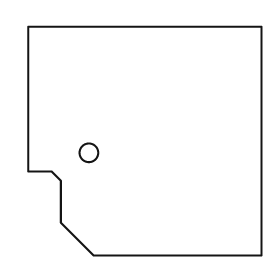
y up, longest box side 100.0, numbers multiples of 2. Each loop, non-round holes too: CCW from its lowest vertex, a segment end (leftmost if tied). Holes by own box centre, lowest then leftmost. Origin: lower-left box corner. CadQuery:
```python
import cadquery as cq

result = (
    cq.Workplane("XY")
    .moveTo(28.0, 0.0)
    .lineTo(100.0, 0.0)
    .lineTo(100.0, 98.0)
    .lineTo(0.0, 98.0)
    .lineTo(0.0, 36.0)
    .lineTo(10.0, 36.0)
    .lineTo(14.0, 32.0)
    .lineTo(14.0, 14.0)
    .close()
    .moveTo(26.0, 44.0)
    .circle(4.0)
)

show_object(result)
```